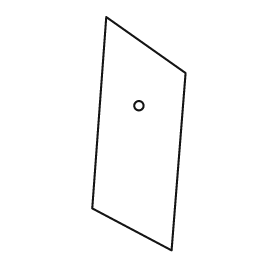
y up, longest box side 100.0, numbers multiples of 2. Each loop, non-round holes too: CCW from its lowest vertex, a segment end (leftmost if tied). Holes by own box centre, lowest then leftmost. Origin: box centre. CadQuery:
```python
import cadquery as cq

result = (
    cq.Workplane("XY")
    .moveTo(14.0, -50.0)
    .lineTo(20.0, 26.0)
    .lineTo(-14.0, 50.0)
    .lineTo(-20.0, -32.0)
    .close()
    .moveTo(0.0, 12.0)
    .circle(2.0)
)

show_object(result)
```